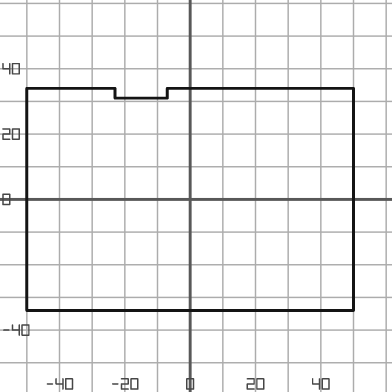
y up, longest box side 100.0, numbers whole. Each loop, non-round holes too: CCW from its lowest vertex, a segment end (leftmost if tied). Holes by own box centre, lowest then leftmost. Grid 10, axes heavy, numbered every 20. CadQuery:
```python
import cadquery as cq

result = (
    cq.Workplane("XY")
    .moveTo(-50.0, -34.0)
    .lineTo(50.0, -34.0)
    .lineTo(50.0, 34.0)
    .lineTo(-7.0, 34.0)
    .lineTo(-7.0, 31.0)
    .lineTo(-23.0, 31.0)
    .lineTo(-23.0, 34.0)
    .lineTo(-50.0, 34.0)
    .close()
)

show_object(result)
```